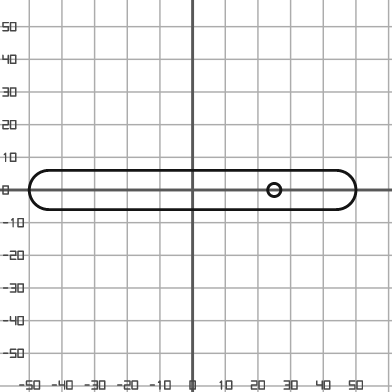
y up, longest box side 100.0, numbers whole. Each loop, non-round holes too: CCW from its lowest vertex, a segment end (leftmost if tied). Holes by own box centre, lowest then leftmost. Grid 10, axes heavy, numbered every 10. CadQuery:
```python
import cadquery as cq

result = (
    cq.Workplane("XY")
    .moveTo(-44.0, -6.0)
    .lineTo(44.0, -6.0)
    .threePointArc((50.0, 0.0), (44.0, 6.0))
    .lineTo(-44.0, 6.0)
    .threePointArc((-50.0, 0.0), (-44.0, -6.0))
    .close()
    .moveTo(25.0, 0.0)
    .circle(2.0)
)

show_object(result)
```